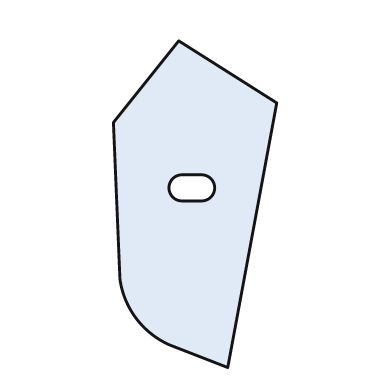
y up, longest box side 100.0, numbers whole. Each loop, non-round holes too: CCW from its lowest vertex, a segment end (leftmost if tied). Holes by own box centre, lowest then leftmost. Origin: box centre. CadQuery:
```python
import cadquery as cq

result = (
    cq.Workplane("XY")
    .moveTo(10.0, -50.0)
    .lineTo(25.0, 31.0)
    .lineTo(-5.0, 50.0)
    .lineTo(-25.0, 25.0)
    .lineTo(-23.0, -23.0)
    .threePointArc((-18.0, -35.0), (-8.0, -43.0))
    .close()
    .moveTo(-4.0, 1.0)
    .lineTo(2.0, 1.0)
    .threePointArc((6.0, 5.0), (2.0, 9.0))
    .lineTo(-4.0, 9.0)
    .threePointArc((-8.0, 5.0), (-4.0, 1.0))
    .close()
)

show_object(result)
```